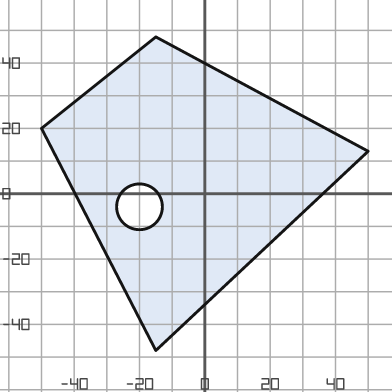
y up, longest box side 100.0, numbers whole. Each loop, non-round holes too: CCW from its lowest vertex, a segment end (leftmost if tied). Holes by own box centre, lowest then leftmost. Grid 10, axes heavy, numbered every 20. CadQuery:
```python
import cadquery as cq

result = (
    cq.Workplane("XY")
    .moveTo(-15.0, -48.0)
    .lineTo(50.0, 13.0)
    .lineTo(-15.0, 48.0)
    .lineTo(-50.0, 20.0)
    .close()
    .moveTo(-20.0, -4.0)
    .circle(7.0)
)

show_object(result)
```